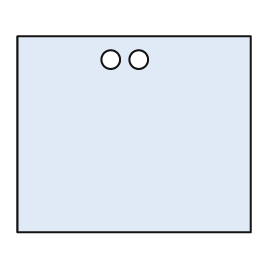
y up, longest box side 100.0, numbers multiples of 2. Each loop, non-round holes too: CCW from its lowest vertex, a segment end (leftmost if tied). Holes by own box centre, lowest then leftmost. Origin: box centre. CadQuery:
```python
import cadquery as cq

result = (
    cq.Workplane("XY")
    .moveTo(-50.0, -42.0)
    .lineTo(50.0, -42.0)
    .lineTo(50.0, 42.0)
    .lineTo(-50.0, 42.0)
    .close()
    .moveTo(-10.0, 32.0)
    .circle(4.0)
    .moveTo(2.0, 32.0)
    .circle(4.0)
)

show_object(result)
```